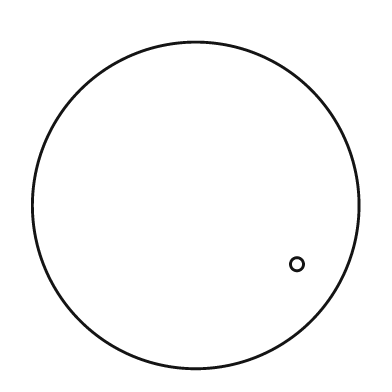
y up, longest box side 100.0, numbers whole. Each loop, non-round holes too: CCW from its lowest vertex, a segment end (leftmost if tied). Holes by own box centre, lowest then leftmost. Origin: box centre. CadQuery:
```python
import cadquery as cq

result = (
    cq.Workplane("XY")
    .moveTo(0.0, 0.0)
    .circle(50.0)
    .moveTo(31.0, -18.0)
    .circle(2.0)
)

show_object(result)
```